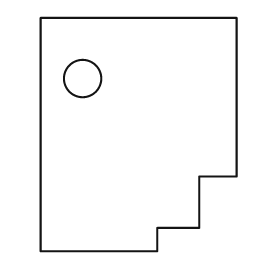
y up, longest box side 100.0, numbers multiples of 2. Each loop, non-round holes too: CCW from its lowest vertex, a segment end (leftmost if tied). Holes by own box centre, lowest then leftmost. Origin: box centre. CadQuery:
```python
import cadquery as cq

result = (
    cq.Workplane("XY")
    .moveTo(-42.0, -50.0)
    .lineTo(8.0, -50.0)
    .lineTo(8.0, -40.0)
    .lineTo(26.0, -40.0)
    .lineTo(26.0, -18.0)
    .lineTo(42.0, -18.0)
    .lineTo(42.0, 50.0)
    .lineTo(-42.0, 50.0)
    .close()
    .moveTo(-24.0, 24.0)
    .circle(8.0)
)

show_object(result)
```